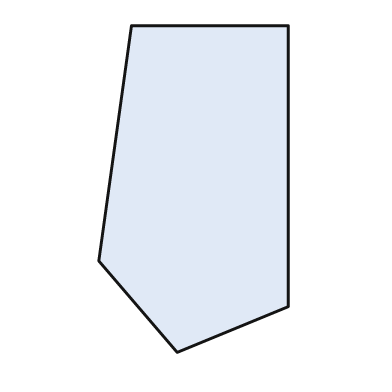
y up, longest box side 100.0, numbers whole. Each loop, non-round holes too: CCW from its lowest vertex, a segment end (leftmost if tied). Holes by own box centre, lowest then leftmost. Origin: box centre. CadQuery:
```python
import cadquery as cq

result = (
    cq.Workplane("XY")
    .moveTo(-5.0, -50.0)
    .lineTo(29.0, -36.0)
    .lineTo(29.0, 50.0)
    .lineTo(-19.0, 50.0)
    .lineTo(-29.0, -22.0)
    .close()
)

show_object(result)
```